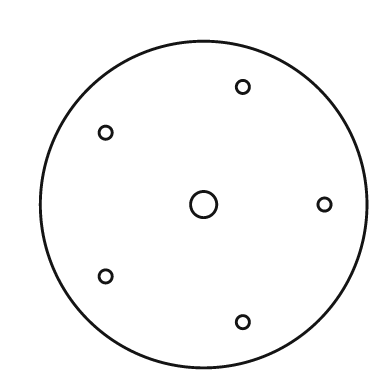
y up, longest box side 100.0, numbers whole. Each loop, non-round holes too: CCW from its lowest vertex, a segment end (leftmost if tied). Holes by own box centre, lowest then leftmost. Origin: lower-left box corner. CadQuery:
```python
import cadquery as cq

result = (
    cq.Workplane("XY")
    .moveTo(50.0, 50.0)
    .circle(50.0)
    .moveTo(62.0, 14.0)
    .circle(2.0)
    .moveTo(20.0, 28.0)
    .circle(2.0)
    .moveTo(50.0, 50.0)
    .circle(4.0)
    .moveTo(87.0, 50.0)
    .circle(2.0)
    .moveTo(20.0, 72.0)
    .circle(2.0)
    .moveTo(62.0, 86.0)
    .circle(2.0)
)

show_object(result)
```